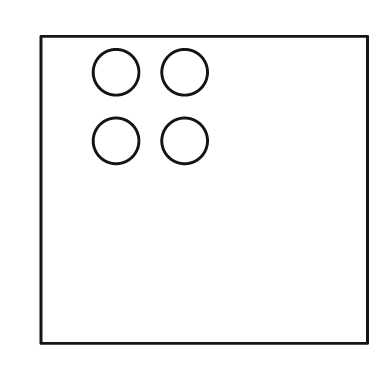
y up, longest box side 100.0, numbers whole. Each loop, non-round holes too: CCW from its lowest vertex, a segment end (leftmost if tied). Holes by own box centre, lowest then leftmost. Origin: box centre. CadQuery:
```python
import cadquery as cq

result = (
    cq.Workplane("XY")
    .moveTo(-50.0, -47.0)
    .lineTo(50.0, -47.0)
    .lineTo(50.0, 47.0)
    .lineTo(-50.0, 47.0)
    .close()
    .moveTo(-27.0, 15.0)
    .circle(7.0)
    .moveTo(-6.0, 15.0)
    .circle(7.0)
    .moveTo(-27.0, 36.0)
    .circle(7.0)
    .moveTo(-6.0, 36.0)
    .circle(7.0)
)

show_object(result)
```